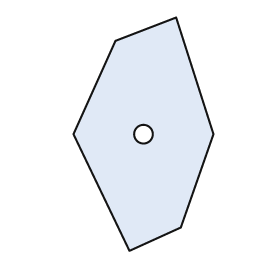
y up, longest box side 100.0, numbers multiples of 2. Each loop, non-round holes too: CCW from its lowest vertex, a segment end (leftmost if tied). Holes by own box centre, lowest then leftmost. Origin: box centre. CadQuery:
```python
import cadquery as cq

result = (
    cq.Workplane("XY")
    .moveTo(-6.0, -50.0)
    .lineTo(16.0, -40.0)
    .lineTo(30.0, 0.0)
    .lineTo(14.0, 50.0)
    .lineTo(-12.0, 40.0)
    .lineTo(-30.0, 0.0)
    .close()
    .moveTo(0.0, 0.0)
    .circle(4.0)
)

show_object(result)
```